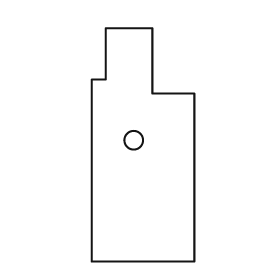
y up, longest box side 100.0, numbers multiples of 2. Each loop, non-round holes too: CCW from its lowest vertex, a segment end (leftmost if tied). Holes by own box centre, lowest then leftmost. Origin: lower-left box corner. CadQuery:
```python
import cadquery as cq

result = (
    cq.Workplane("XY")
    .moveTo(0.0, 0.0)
    .lineTo(44.0, 0.0)
    .lineTo(44.0, 72.0)
    .lineTo(26.0, 72.0)
    .lineTo(26.0, 100.0)
    .lineTo(6.0, 100.0)
    .lineTo(6.0, 78.0)
    .lineTo(0.0, 78.0)
    .close()
    .moveTo(18.0, 52.0)
    .circle(4.0)
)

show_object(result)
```